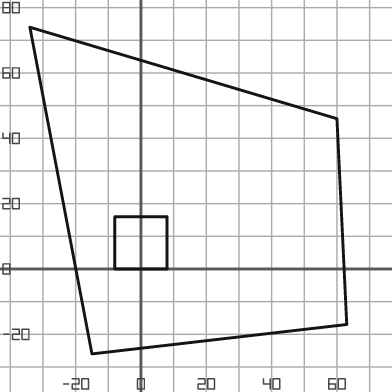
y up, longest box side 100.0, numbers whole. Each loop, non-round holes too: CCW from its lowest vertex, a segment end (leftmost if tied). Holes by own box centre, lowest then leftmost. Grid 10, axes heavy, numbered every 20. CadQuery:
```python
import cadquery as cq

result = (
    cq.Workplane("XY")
    .moveTo(-15.0, -26.0)
    .lineTo(63.0, -17.0)
    .lineTo(60.0, 46.0)
    .lineTo(-34.0, 74.0)
    .close()
    .moveTo(-8.0, 0.0)
    .lineTo(8.0, 0.0)
    .lineTo(8.0, 16.0)
    .lineTo(-8.0, 16.0)
    .close()
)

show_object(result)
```